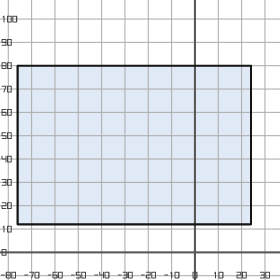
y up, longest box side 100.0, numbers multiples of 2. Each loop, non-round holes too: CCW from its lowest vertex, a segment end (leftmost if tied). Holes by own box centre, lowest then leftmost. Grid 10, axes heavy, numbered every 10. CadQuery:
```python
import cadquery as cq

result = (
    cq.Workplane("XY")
    .moveTo(-76.0, 12.0)
    .lineTo(24.0, 12.0)
    .lineTo(24.0, 80.0)
    .lineTo(-76.0, 80.0)
    .close()
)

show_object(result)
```